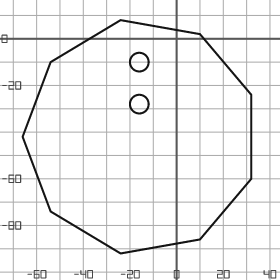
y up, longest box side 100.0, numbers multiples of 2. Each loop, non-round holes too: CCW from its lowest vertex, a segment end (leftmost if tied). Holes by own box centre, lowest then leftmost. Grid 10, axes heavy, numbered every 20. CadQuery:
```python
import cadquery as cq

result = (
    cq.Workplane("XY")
    .moveTo(-24.0, -92.0)
    .lineTo(10.0, -86.0)
    .lineTo(32.0, -60.0)
    .lineTo(32.0, -24.0)
    .lineTo(10.0, 2.0)
    .lineTo(-24.0, 8.0)
    .lineTo(-54.0, -10.0)
    .lineTo(-66.0, -42.0)
    .lineTo(-54.0, -74.0)
    .close()
    .moveTo(-16.0, -28.0)
    .circle(4.0)
    .moveTo(-16.0, -10.0)
    .circle(4.0)
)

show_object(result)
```